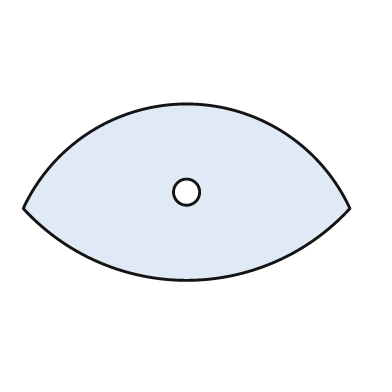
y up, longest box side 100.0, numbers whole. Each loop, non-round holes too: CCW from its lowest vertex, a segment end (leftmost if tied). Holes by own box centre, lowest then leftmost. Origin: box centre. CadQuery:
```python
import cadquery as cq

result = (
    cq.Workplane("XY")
    .moveTo(-50.0, -5.0)
    .threePointArc((0.0, -27.0), (50.0, -5.0))
    .threePointArc((0.0, 27.0), (-50.0, -5.0))
    .close()
    .moveTo(0.0, 0.0)
    .circle(4.0)
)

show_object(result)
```